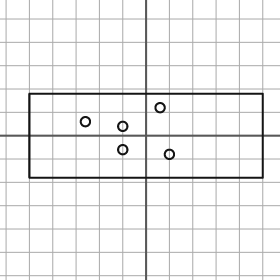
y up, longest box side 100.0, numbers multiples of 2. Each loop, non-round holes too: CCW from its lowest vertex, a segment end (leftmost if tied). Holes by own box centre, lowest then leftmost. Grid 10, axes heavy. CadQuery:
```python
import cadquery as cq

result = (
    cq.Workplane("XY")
    .moveTo(-50.0, -18.0)
    .lineTo(50.0, -18.0)
    .lineTo(50.0, 18.0)
    .lineTo(-50.0, 18.0)
    .close()
    .moveTo(10.0, -8.0)
    .circle(2.0)
    .moveTo(-10.0, -6.0)
    .circle(2.0)
    .moveTo(-10.0, 4.0)
    .circle(2.0)
    .moveTo(-26.0, 6.0)
    .circle(2.0)
    .moveTo(6.0, 12.0)
    .circle(2.0)
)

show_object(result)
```